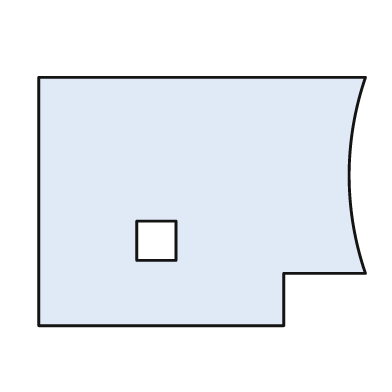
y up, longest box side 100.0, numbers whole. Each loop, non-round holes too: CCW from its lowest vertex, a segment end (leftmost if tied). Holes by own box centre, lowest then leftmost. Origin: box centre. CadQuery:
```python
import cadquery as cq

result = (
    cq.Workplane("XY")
    .moveTo(-50.0, -38.0)
    .lineTo(25.0, -38.0)
    .lineTo(25.0, -22.0)
    .lineTo(50.0, -22.0)
    .threePointArc((45.0, 8.0), (50.0, 38.0))
    .lineTo(-50.0, 38.0)
    .close()
    .moveTo(-20.0, -18.0)
    .lineTo(-8.0, -18.0)
    .lineTo(-8.0, -6.0)
    .lineTo(-20.0, -6.0)
    .close()
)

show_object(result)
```